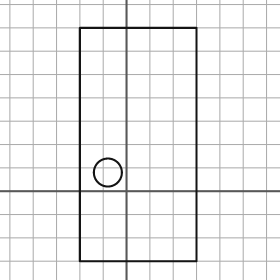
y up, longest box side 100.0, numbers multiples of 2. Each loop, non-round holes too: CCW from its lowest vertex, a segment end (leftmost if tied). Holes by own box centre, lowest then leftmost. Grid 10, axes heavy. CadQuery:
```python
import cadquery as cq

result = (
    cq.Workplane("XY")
    .moveTo(-20.0, -30.0)
    .lineTo(30.0, -30.0)
    .lineTo(30.0, 70.0)
    .lineTo(-20.0, 70.0)
    .close()
    .moveTo(-8.0, 8.0)
    .circle(6.0)
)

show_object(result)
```